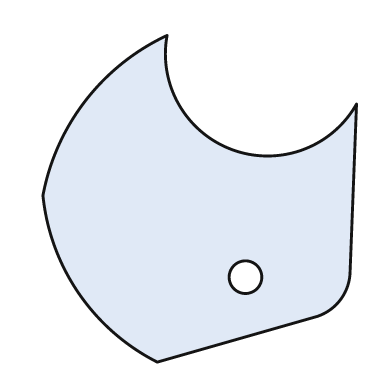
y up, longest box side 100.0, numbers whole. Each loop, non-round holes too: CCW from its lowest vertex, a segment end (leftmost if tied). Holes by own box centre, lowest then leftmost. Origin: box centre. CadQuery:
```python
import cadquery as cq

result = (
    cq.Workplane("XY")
    .moveTo(-13.0, -50.0)
    .lineTo(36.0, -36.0)
    .threePointArc((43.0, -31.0), (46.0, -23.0))
    .lineTo(48.0, 29.0)
    .threePointArc((10.0, 15.0), (-10.0, 50.0))
    .threePointArc((-35.0, 30.0), (-48.0, 1.0))
    .threePointArc((-37.0, -29.0), (-13.0, -50.0))
    .close()
    .moveTo(14.0, -24.0)
    .circle(5.0)
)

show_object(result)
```